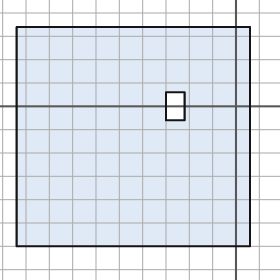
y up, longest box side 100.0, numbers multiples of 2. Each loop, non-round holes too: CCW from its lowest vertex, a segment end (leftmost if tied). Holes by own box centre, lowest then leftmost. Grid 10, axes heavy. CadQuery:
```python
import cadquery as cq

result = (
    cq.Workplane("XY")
    .moveTo(-94.0, -60.0)
    .lineTo(6.0, -60.0)
    .lineTo(6.0, 34.0)
    .lineTo(-94.0, 34.0)
    .close()
    .moveTo(-30.0, -6.0)
    .lineTo(-22.0, -6.0)
    .lineTo(-22.0, 6.0)
    .lineTo(-30.0, 6.0)
    .close()
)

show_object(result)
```